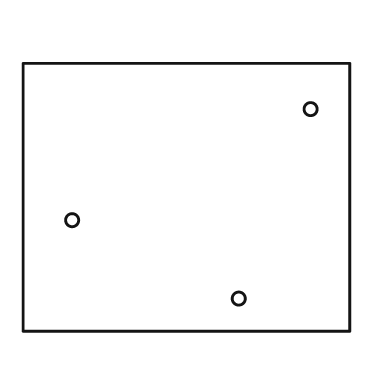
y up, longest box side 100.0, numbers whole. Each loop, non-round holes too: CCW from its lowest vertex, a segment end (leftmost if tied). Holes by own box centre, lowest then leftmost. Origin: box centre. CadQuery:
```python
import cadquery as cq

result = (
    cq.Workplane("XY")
    .moveTo(-50.0, -41.0)
    .lineTo(50.0, -41.0)
    .lineTo(50.0, 41.0)
    .lineTo(-50.0, 41.0)
    .close()
    .moveTo(16.0, -31.0)
    .circle(2.0)
    .moveTo(-35.0, -7.0)
    .circle(2.0)
    .moveTo(38.0, 27.0)
    .circle(2.0)
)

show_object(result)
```